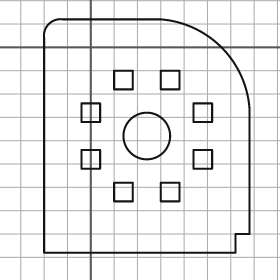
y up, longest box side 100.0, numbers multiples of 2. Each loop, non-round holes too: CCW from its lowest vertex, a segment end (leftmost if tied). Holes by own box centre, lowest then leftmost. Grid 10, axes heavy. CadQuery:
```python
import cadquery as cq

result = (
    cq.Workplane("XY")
    .moveTo(-20.0, -88.0)
    .lineTo(62.0, -88.0)
    .lineTo(62.0, -80.0)
    .lineTo(68.0, -80.0)
    .lineTo(68.0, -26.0)
    .threePointArc((56.0, 0.0), (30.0, 12.0))
    .lineTo(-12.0, 12.0)
    .threePointArc((-18.0, 10.0), (-20.0, 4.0))
    .close()
    .moveTo(10.0, -66.0)
    .lineTo(18.0, -66.0)
    .lineTo(18.0, -58.0)
    .lineTo(10.0, -58.0)
    .close()
    .moveTo(30.0, -66.0)
    .lineTo(38.0, -66.0)
    .lineTo(38.0, -58.0)
    .lineTo(30.0, -58.0)
    .close()
    .moveTo(-4.0, -52.0)
    .lineTo(4.0, -52.0)
    .lineTo(4.0, -44.0)
    .lineTo(-4.0, -44.0)
    .close()
    .moveTo(44.0, -52.0)
    .lineTo(52.0, -52.0)
    .lineTo(52.0, -44.0)
    .lineTo(44.0, -44.0)
    .close()
    .moveTo(24.0, -38.0)
    .circle(10.0)
    .moveTo(-4.0, -32.0)
    .lineTo(4.0, -32.0)
    .lineTo(4.0, -24.0)
    .lineTo(-4.0, -24.0)
    .close()
    .moveTo(44.0, -32.0)
    .lineTo(52.0, -32.0)
    .lineTo(52.0, -24.0)
    .lineTo(44.0, -24.0)
    .close()
    .moveTo(10.0, -18.0)
    .lineTo(18.0, -18.0)
    .lineTo(18.0, -10.0)
    .lineTo(10.0, -10.0)
    .close()
    .moveTo(30.0, -18.0)
    .lineTo(38.0, -18.0)
    .lineTo(38.0, -10.0)
    .lineTo(30.0, -10.0)
    .close()
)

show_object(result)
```